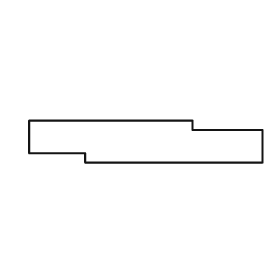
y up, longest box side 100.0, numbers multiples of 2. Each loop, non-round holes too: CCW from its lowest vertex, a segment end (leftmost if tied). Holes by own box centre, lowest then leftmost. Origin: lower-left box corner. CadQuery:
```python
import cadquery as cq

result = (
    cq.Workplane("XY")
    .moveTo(24.0, 0.0)
    .lineTo(100.0, 0.0)
    .lineTo(100.0, 14.0)
    .lineTo(70.0, 14.0)
    .lineTo(70.0, 18.0)
    .lineTo(0.0, 18.0)
    .lineTo(0.0, 4.0)
    .lineTo(24.0, 4.0)
    .close()
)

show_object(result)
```